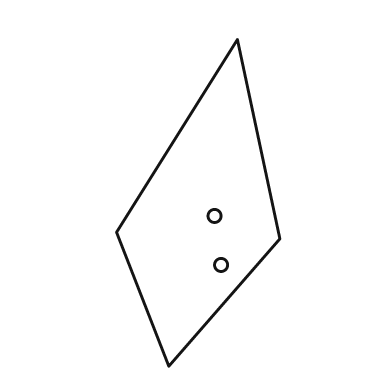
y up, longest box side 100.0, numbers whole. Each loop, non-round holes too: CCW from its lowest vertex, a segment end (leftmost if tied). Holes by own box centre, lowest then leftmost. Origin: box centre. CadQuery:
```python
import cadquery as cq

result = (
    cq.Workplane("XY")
    .moveTo(-9.0, -50.0)
    .lineTo(25.0, -11.0)
    .lineTo(12.0, 50.0)
    .lineTo(-25.0, -9.0)
    .close()
    .moveTo(7.0, -19.0)
    .circle(2.0)
    .moveTo(5.0, -4.0)
    .circle(2.0)
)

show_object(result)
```